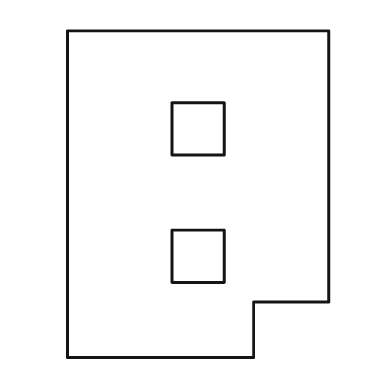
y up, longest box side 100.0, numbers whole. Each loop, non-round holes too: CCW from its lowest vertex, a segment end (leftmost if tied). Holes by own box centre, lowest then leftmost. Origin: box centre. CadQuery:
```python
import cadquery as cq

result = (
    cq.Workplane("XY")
    .moveTo(-40.0, -50.0)
    .lineTo(17.0, -50.0)
    .lineTo(17.0, -33.0)
    .lineTo(40.0, -33.0)
    .lineTo(40.0, 50.0)
    .lineTo(-40.0, 50.0)
    .close()
    .moveTo(-8.0, -27.0)
    .lineTo(8.0, -27.0)
    .lineTo(8.0, -11.0)
    .lineTo(-8.0, -11.0)
    .close()
    .moveTo(-8.0, 12.0)
    .lineTo(8.0, 12.0)
    .lineTo(8.0, 28.0)
    .lineTo(-8.0, 28.0)
    .close()
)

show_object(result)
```